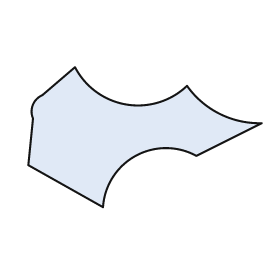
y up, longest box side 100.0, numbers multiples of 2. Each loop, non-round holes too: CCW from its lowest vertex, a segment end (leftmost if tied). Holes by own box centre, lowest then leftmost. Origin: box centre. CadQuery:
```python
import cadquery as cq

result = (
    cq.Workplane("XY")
    .moveTo(-18.0, -30.0)
    .threePointArc((-4.0, -8.0), (22.0, -8.0))
    .lineTo(50.0, 6.0)
    .threePointArc((32.0, 10.0), (18.0, 22.0))
    .threePointArc((-8.0, 14.0), (-30.0, 30.0))
    .lineTo(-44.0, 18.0)
    .threePointArc((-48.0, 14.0), (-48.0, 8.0))
    .lineTo(-50.0, -12.0)
    .close()
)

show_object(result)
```